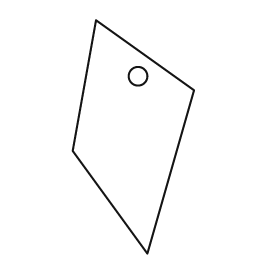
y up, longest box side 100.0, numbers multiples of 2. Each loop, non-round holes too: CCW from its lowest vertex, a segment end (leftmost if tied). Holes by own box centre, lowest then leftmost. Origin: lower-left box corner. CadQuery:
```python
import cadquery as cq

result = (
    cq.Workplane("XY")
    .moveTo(32.0, 0.0)
    .lineTo(52.0, 70.0)
    .lineTo(10.0, 100.0)
    .lineTo(0.0, 44.0)
    .close()
    .moveTo(28.0, 76.0)
    .circle(4.0)
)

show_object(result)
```